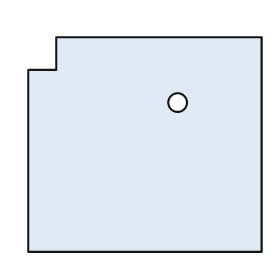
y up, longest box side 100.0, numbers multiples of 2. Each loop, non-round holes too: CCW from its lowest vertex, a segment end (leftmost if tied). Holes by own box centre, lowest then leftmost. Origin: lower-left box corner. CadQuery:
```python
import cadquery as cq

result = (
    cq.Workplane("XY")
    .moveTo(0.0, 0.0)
    .lineTo(100.0, 0.0)
    .lineTo(100.0, 92.0)
    .lineTo(12.0, 92.0)
    .lineTo(12.0, 78.0)
    .lineTo(0.0, 78.0)
    .close()
    .moveTo(64.0, 64.0)
    .circle(4.0)
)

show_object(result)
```